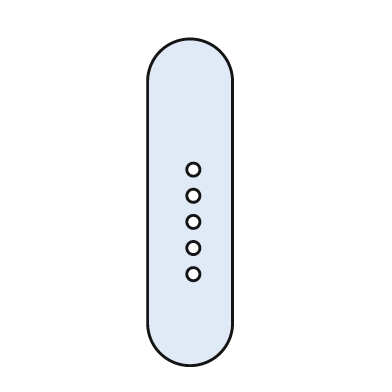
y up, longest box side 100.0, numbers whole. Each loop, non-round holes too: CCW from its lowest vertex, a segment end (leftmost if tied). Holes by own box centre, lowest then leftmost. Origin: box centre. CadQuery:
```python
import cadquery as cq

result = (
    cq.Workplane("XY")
    .moveTo(-13.0, -37.0)
    .threePointArc((0.0, -50.0), (13.0, -37.0))
    .lineTo(13.0, 37.0)
    .threePointArc((0.0, 50.0), (-13.0, 37.0))
    .close()
    .moveTo(1.0, -22.0)
    .circle(2.0)
    .moveTo(1.0, -14.0)
    .circle(2.0)
    .moveTo(1.0, -6.0)
    .circle(2.0)
    .moveTo(1.0, 2.0)
    .circle(2.0)
    .moveTo(1.0, 10.0)
    .circle(2.0)
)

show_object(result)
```